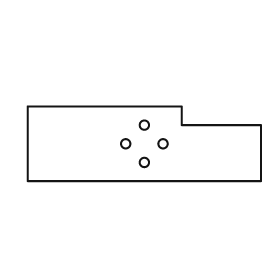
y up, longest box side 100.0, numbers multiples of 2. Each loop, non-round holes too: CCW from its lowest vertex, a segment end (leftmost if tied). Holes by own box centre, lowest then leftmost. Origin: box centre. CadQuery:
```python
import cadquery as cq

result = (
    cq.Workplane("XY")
    .moveTo(-50.0, -16.0)
    .lineTo(50.0, -16.0)
    .lineTo(50.0, 8.0)
    .lineTo(16.0, 8.0)
    .lineTo(16.0, 16.0)
    .lineTo(-50.0, 16.0)
    .close()
    .moveTo(0.0, -8.0)
    .circle(2.0)
    .moveTo(-8.0, 0.0)
    .circle(2.0)
    .moveTo(8.0, 0.0)
    .circle(2.0)
    .moveTo(0.0, 8.0)
    .circle(2.0)
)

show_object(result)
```